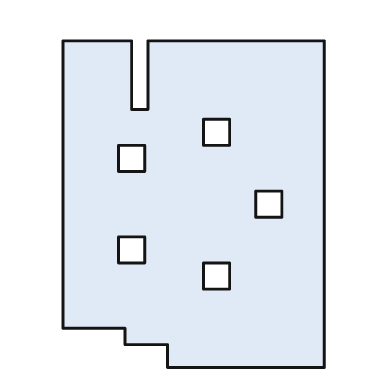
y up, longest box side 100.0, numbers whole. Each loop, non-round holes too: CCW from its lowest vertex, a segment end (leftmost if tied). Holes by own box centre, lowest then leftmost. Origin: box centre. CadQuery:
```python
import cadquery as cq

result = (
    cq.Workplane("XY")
    .moveTo(-8.0, -50.0)
    .lineTo(40.0, -50.0)
    .lineTo(40.0, 50.0)
    .lineTo(-14.0, 50.0)
    .lineTo(-14.0, 29.0)
    .lineTo(-19.0, 29.0)
    .lineTo(-19.0, 50.0)
    .lineTo(-40.0, 50.0)
    .lineTo(-40.0, -38.0)
    .lineTo(-21.0, -38.0)
    .lineTo(-21.0, -43.0)
    .lineTo(-8.0, -43.0)
    .close()
    .moveTo(3.0, -26.0)
    .lineTo(11.0, -26.0)
    .lineTo(11.0, -18.0)
    .lineTo(3.0, -18.0)
    .close()
    .moveTo(-23.0, -18.0)
    .lineTo(-15.0, -18.0)
    .lineTo(-15.0, -10.0)
    .lineTo(-23.0, -10.0)
    .close()
    .moveTo(19.0, -4.0)
    .lineTo(27.0, -4.0)
    .lineTo(27.0, 4.0)
    .lineTo(19.0, 4.0)
    .close()
    .moveTo(-23.0, 10.0)
    .lineTo(-15.0, 10.0)
    .lineTo(-15.0, 18.0)
    .lineTo(-23.0, 18.0)
    .close()
    .moveTo(3.0, 18.0)
    .lineTo(11.0, 18.0)
    .lineTo(11.0, 26.0)
    .lineTo(3.0, 26.0)
    .close()
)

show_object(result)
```